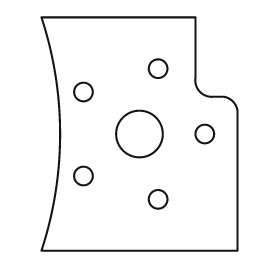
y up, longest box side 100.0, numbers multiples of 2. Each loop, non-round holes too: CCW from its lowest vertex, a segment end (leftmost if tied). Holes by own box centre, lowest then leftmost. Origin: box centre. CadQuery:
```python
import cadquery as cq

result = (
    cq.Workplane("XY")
    .moveTo(-42.0, -50.0)
    .lineTo(42.0, -50.0)
    .lineTo(42.0, 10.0)
    .threePointArc((40.0, 14.0), (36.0, 16.0))
    .lineTo(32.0, 16.0)
    .threePointArc((26.0, 18.0), (24.0, 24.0))
    .lineTo(24.0, 50.0)
    .lineTo(-42.0, 50.0)
    .threePointArc((-34.0, 0.0), (-42.0, -50.0))
    .close()
    .moveTo(8.0, -28.0)
    .circle(4.0)
    .moveTo(-24.0, -18.0)
    .circle(4.0)
    .moveTo(0.0, 0.0)
    .circle(10.0)
    .moveTo(28.0, 0.0)
    .circle(4.0)
    .moveTo(-24.0, 18.0)
    .circle(4.0)
    .moveTo(8.0, 28.0)
    .circle(4.0)
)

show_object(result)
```